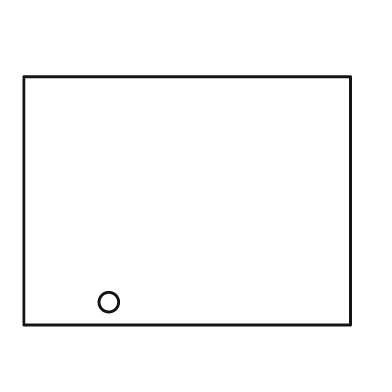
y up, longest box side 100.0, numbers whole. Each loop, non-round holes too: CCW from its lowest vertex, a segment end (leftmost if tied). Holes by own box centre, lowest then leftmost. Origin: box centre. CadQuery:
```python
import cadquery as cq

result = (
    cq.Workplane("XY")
    .moveTo(-50.0, -38.0)
    .lineTo(50.0, -38.0)
    .lineTo(50.0, 38.0)
    .lineTo(-50.0, 38.0)
    .close()
    .moveTo(-24.0, -31.0)
    .circle(3.0)
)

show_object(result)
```